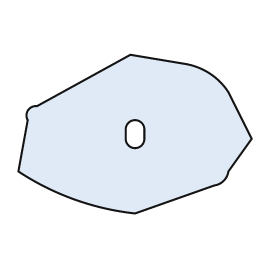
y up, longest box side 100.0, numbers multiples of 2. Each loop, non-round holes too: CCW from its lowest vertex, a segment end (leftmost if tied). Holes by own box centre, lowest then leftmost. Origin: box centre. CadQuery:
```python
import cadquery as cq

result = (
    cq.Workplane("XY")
    .moveTo(0.0, -34.0)
    .lineTo(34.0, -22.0)
    .threePointArc((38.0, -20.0), (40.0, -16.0))
    .lineTo(50.0, -2.0)
    .lineTo(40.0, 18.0)
    .threePointArc((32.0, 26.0), (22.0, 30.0))
    .lineTo(-2.0, 34.0)
    .lineTo(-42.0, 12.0)
    .threePointArc((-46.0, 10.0), (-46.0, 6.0))
    .lineTo(-50.0, -16.0)
    .threePointArc((-26.0, -28.0), (0.0, -34.0))
    .close()
    .moveTo(-4.0, -2.0)
    .threePointArc((0.0, -6.0), (4.0, -2.0))
    .lineTo(4.0, 2.0)
    .threePointArc((0.0, 6.0), (-4.0, 2.0))
    .close()
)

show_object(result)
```